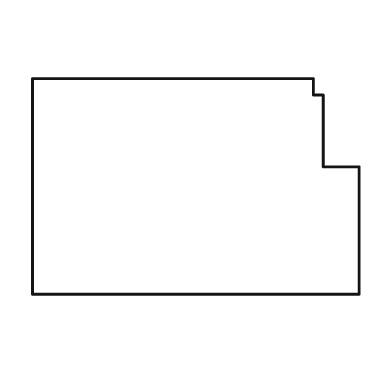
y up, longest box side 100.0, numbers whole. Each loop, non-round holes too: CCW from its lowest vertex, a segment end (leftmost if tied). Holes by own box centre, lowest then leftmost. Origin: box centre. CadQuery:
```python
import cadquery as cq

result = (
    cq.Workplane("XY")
    .moveTo(-50.0, -33.0)
    .lineTo(50.0, -33.0)
    .lineTo(50.0, 6.0)
    .lineTo(39.0, 6.0)
    .lineTo(39.0, 28.0)
    .lineTo(36.0, 28.0)
    .lineTo(36.0, 33.0)
    .lineTo(-50.0, 33.0)
    .close()
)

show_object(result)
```